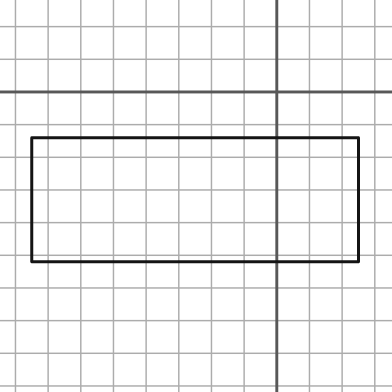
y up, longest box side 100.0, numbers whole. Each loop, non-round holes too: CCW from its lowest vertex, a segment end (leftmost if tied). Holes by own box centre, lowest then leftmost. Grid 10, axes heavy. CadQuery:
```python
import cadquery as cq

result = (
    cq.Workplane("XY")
    .moveTo(-75.0, -52.0)
    .lineTo(25.0, -52.0)
    .lineTo(25.0, -14.0)
    .lineTo(-75.0, -14.0)
    .close()
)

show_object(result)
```